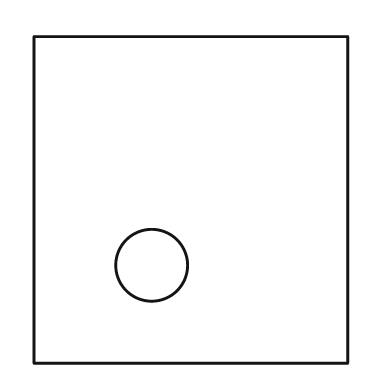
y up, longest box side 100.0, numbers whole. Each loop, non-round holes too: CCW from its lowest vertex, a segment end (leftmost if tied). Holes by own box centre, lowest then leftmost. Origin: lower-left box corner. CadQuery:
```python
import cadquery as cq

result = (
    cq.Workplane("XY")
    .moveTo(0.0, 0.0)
    .lineTo(96.0, 0.0)
    .lineTo(96.0, 100.0)
    .lineTo(0.0, 100.0)
    .close()
    .moveTo(36.0, 30.0)
    .circle(11.0)
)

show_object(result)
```